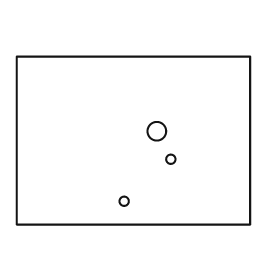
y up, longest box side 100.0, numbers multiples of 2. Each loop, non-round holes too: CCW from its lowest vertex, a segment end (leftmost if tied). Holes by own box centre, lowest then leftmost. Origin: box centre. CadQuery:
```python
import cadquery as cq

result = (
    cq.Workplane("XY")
    .moveTo(-50.0, -36.0)
    .lineTo(50.0, -36.0)
    .lineTo(50.0, 36.0)
    .lineTo(-50.0, 36.0)
    .close()
    .moveTo(-4.0, -26.0)
    .circle(2.0)
    .moveTo(16.0, -8.0)
    .circle(2.0)
    .moveTo(10.0, 4.0)
    .circle(4.0)
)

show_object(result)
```